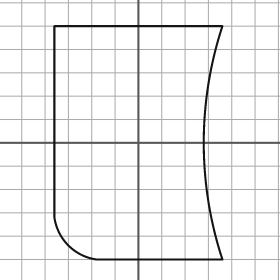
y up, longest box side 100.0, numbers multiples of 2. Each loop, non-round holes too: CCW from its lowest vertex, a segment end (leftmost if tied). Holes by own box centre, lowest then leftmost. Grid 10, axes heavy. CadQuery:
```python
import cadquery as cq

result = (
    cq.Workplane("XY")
    .moveTo(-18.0, -50.0)
    .lineTo(36.0, -50.0)
    .threePointArc((28.0, 0.0), (36.0, 50.0))
    .lineTo(-36.0, 50.0)
    .lineTo(-36.0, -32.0)
    .threePointArc((-30.0, -44.0), (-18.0, -50.0))
    .close()
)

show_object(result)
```